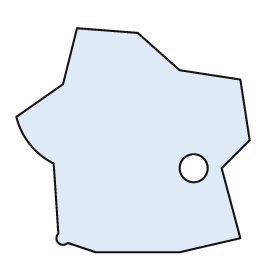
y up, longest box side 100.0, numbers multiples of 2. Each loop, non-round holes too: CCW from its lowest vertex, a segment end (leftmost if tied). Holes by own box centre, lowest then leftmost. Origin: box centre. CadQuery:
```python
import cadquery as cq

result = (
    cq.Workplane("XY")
    .moveTo(-16.0, -48.0)
    .lineTo(20.0, -48.0)
    .lineTo(46.0, -42.0)
    .lineTo(38.0, -12.0)
    .lineTo(50.0, 0.0)
    .lineTo(46.0, 26.0)
    .lineTo(20.0, 30.0)
    .lineTo(2.0, 46.0)
    .lineTo(-24.0, 48.0)
    .lineTo(-30.0, 24.0)
    .lineTo(-50.0, 10.0)
    .threePointArc((-44.0, -2.0), (-34.0, -10.0))
    .lineTo(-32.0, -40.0)
    .threePointArc((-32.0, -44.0), (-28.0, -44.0))
    .close()
    .moveTo(26.0, -12.0)
    .circle(6.0)
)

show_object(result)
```